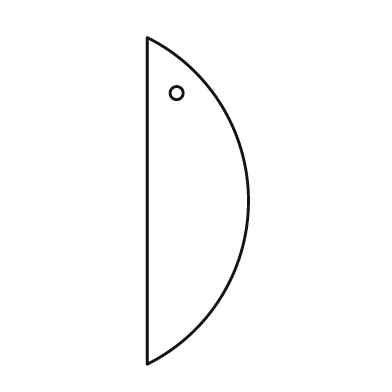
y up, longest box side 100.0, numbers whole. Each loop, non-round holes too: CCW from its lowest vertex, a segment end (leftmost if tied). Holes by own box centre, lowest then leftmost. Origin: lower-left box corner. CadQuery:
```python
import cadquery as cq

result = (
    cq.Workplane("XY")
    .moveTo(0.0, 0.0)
    .threePointArc((31.0, 50.0), (0.0, 100.0))
    .close()
    .moveTo(9.0, 83.0)
    .circle(2.0)
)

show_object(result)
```